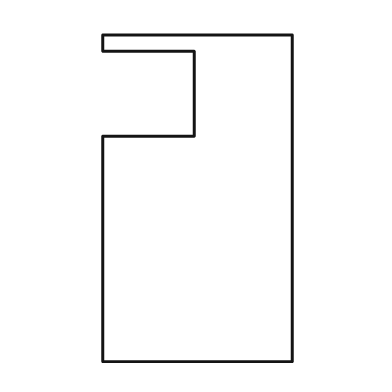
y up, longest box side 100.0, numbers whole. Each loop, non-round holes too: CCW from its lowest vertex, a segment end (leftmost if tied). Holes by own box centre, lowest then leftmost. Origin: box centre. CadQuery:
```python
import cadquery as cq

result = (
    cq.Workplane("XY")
    .moveTo(-29.0, -50.0)
    .lineTo(29.0, -50.0)
    .lineTo(29.0, 50.0)
    .lineTo(-29.0, 50.0)
    .lineTo(-29.0, 45.0)
    .lineTo(-1.0, 45.0)
    .lineTo(-1.0, 19.0)
    .lineTo(-29.0, 19.0)
    .close()
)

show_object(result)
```